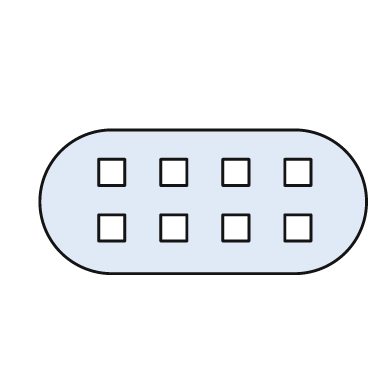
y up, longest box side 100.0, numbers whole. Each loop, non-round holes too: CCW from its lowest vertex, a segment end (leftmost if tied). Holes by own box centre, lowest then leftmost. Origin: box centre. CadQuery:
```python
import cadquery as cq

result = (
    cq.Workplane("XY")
    .moveTo(-28.0, -22.0)
    .lineTo(28.0, -22.0)
    .threePointArc((50.0, 0.0), (28.0, 22.0))
    .lineTo(-28.0, 22.0)
    .threePointArc((-50.0, 0.0), (-28.0, -22.0))
    .close()
    .moveTo(-32.0, -12.0)
    .lineTo(-24.0, -12.0)
    .lineTo(-24.0, -4.0)
    .lineTo(-32.0, -4.0)
    .close()
    .moveTo(-13.0, -12.0)
    .lineTo(-5.0, -12.0)
    .lineTo(-5.0, -4.0)
    .lineTo(-13.0, -4.0)
    .close()
    .moveTo(6.0, -12.0)
    .lineTo(14.0, -12.0)
    .lineTo(14.0, -4.0)
    .lineTo(6.0, -4.0)
    .close()
    .moveTo(25.0, -12.0)
    .lineTo(33.0, -12.0)
    .lineTo(33.0, -4.0)
    .lineTo(25.0, -4.0)
    .close()
    .moveTo(-32.0, 5.0)
    .lineTo(-24.0, 5.0)
    .lineTo(-24.0, 13.0)
    .lineTo(-32.0, 13.0)
    .close()
    .moveTo(-13.0, 5.0)
    .lineTo(-5.0, 5.0)
    .lineTo(-5.0, 13.0)
    .lineTo(-13.0, 13.0)
    .close()
    .moveTo(6.0, 5.0)
    .lineTo(14.0, 5.0)
    .lineTo(14.0, 13.0)
    .lineTo(6.0, 13.0)
    .close()
    .moveTo(25.0, 5.0)
    .lineTo(33.0, 5.0)
    .lineTo(33.0, 13.0)
    .lineTo(25.0, 13.0)
    .close()
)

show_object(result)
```